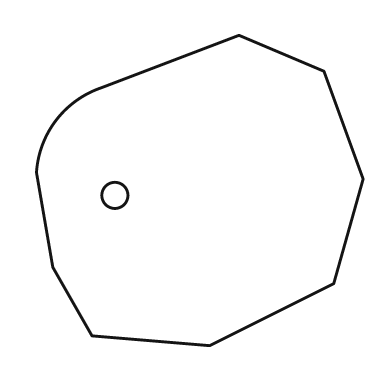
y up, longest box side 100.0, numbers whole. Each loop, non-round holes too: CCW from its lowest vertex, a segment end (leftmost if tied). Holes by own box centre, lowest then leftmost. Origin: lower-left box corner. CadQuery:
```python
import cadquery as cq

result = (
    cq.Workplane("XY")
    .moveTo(53.0, 0.0)
    .lineTo(91.0, 19.0)
    .lineTo(100.0, 51.0)
    .lineTo(88.0, 84.0)
    .lineTo(62.0, 95.0)
    .lineTo(20.0, 79.0)
    .threePointArc((6.0, 69.0), (0.0, 53.0))
    .lineTo(5.0, 24.0)
    .lineTo(17.0, 3.0)
    .close()
    .moveTo(24.0, 46.0)
    .circle(4.0)
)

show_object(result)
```